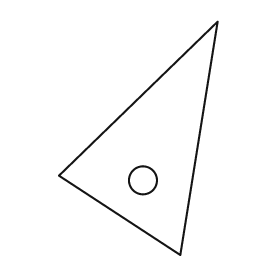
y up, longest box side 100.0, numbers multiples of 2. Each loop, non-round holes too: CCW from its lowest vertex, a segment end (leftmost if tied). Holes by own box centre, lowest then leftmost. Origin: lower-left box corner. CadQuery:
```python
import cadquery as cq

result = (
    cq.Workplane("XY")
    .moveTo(52.0, 0.0)
    .lineTo(68.0, 100.0)
    .lineTo(0.0, 34.0)
    .close()
    .moveTo(36.0, 32.0)
    .circle(6.0)
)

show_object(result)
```